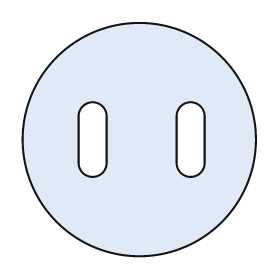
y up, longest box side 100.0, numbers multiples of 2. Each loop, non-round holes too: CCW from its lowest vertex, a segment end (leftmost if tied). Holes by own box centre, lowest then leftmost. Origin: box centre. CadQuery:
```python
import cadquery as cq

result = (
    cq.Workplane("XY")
    .moveTo(0.0, 0.0)
    .circle(50.0)
    .moveTo(-26.0, -10.0)
    .threePointArc((-20.0, -16.0), (-14.0, -10.0))
    .lineTo(-14.0, 10.0)
    .threePointArc((-20.0, 16.0), (-26.0, 10.0))
    .close()
    .moveTo(16.0, -10.0)
    .threePointArc((22.0, -16.0), (28.0, -10.0))
    .lineTo(28.0, 10.0)
    .threePointArc((22.0, 16.0), (16.0, 10.0))
    .close()
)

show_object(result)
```